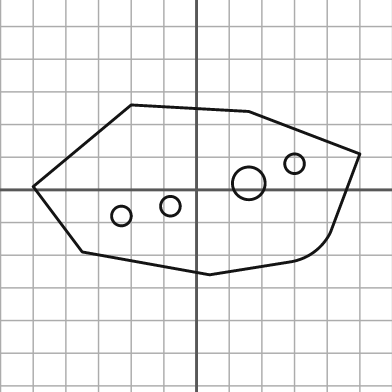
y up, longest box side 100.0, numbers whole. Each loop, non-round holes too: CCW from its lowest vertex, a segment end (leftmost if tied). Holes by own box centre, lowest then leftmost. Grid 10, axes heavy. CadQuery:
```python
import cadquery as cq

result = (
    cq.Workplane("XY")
    .moveTo(4.0, -26.0)
    .lineTo(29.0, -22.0)
    .threePointArc((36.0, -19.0), (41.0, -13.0))
    .lineTo(50.0, 11.0)
    .lineTo(16.0, 24.0)
    .lineTo(-20.0, 26.0)
    .lineTo(-50.0, 1.0)
    .lineTo(-35.0, -19.0)
    .close()
    .moveTo(-23.0, -8.0)
    .circle(3.0)
    .moveTo(-8.0, -5.0)
    .circle(3.0)
    .moveTo(16.0, 2.0)
    .circle(5.0)
    .moveTo(30.0, 8.0)
    .circle(3.0)
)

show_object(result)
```